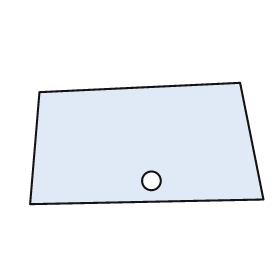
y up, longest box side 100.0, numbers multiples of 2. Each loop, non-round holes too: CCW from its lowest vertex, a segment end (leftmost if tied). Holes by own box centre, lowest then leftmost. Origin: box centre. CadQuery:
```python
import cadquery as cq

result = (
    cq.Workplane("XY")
    .moveTo(-50.0, -26.0)
    .lineTo(50.0, -24.0)
    .lineTo(40.0, 26.0)
    .lineTo(-46.0, 22.0)
    .close()
    .moveTo(2.0, -16.0)
    .circle(4.0)
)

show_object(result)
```